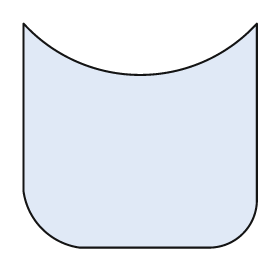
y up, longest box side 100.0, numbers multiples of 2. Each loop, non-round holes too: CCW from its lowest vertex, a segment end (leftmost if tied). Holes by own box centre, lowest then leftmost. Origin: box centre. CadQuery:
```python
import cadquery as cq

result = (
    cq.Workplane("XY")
    .moveTo(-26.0, -48.0)
    .lineTo(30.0, -48.0)
    .threePointArc((44.0, -42.0), (50.0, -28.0))
    .lineTo(50.0, 48.0)
    .threePointArc((0.0, 26.0), (-50.0, 48.0))
    .lineTo(-50.0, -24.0)
    .threePointArc((-42.0, -40.0), (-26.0, -48.0))
    .close()
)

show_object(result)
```